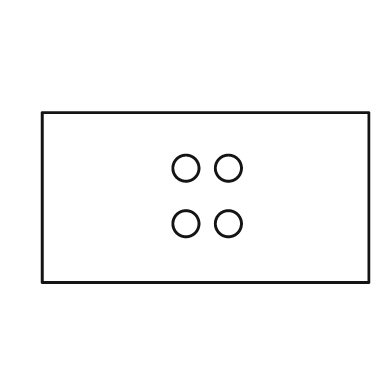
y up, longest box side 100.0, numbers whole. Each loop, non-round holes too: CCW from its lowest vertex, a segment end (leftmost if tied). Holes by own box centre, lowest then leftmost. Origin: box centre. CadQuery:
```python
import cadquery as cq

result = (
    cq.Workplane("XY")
    .moveTo(-50.0, -26.0)
    .lineTo(50.0, -26.0)
    .lineTo(50.0, 26.0)
    .lineTo(-50.0, 26.0)
    .close()
    .moveTo(-6.0, -8.0)
    .circle(4.0)
    .moveTo(7.0, -8.0)
    .circle(4.0)
    .moveTo(-6.0, 9.0)
    .circle(4.0)
    .moveTo(7.0, 9.0)
    .circle(4.0)
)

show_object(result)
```